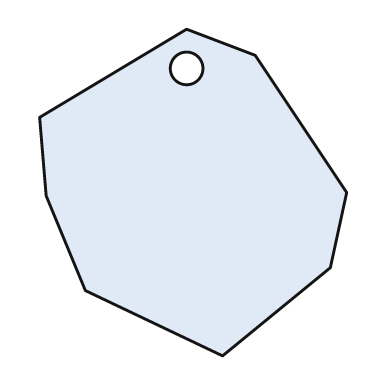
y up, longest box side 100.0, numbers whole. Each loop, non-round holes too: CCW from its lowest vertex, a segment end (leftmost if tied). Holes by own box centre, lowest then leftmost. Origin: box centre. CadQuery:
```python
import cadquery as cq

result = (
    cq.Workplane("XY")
    .moveTo(9.0, -50.0)
    .lineTo(42.0, -23.0)
    .lineTo(47.0, 0.0)
    .lineTo(19.0, 42.0)
    .lineTo(-2.0, 50.0)
    .lineTo(-47.0, 23.0)
    .lineTo(-45.0, -1.0)
    .lineTo(-33.0, -30.0)
    .close()
    .moveTo(-2.0, 38.0)
    .circle(5.0)
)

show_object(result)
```